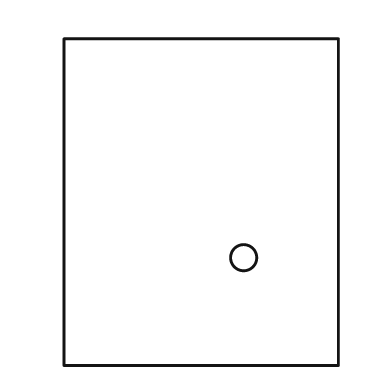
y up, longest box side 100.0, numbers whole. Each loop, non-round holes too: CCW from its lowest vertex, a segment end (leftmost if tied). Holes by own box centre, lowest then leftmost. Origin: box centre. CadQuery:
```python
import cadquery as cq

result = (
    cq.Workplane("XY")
    .moveTo(-42.0, -50.0)
    .lineTo(42.0, -50.0)
    .lineTo(42.0, 50.0)
    .lineTo(-42.0, 50.0)
    .close()
    .moveTo(13.0, -17.0)
    .circle(4.0)
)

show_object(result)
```